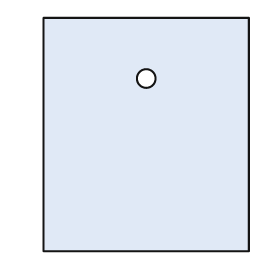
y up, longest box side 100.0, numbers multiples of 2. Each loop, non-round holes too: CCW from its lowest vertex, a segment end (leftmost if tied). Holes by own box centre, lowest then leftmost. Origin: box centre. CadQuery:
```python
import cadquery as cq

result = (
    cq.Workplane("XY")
    .moveTo(-44.0, -50.0)
    .lineTo(44.0, -50.0)
    .lineTo(44.0, 50.0)
    .lineTo(-44.0, 50.0)
    .close()
    .moveTo(0.0, 24.0)
    .circle(4.0)
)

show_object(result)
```